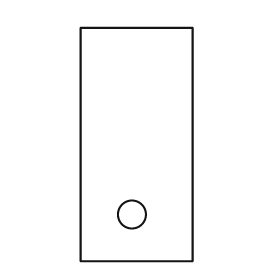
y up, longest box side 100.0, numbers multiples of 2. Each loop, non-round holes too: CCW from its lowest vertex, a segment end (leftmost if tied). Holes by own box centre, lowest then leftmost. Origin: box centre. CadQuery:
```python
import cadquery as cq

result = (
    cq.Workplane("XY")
    .moveTo(-24.0, -50.0)
    .lineTo(24.0, -50.0)
    .lineTo(24.0, 50.0)
    .lineTo(-24.0, 50.0)
    .close()
    .moveTo(-2.0, -30.0)
    .circle(6.0)
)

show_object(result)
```